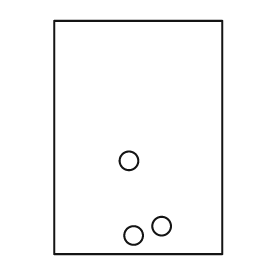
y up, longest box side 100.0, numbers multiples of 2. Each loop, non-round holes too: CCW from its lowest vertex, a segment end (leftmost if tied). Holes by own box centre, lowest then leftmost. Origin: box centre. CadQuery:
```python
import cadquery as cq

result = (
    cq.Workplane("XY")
    .moveTo(-36.0, -50.0)
    .lineTo(36.0, -50.0)
    .lineTo(36.0, 50.0)
    .lineTo(-36.0, 50.0)
    .close()
    .moveTo(-2.0, -42.0)
    .circle(4.0)
    .moveTo(10.0, -38.0)
    .circle(4.0)
    .moveTo(-4.0, -10.0)
    .circle(4.0)
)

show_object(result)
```